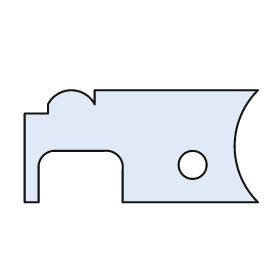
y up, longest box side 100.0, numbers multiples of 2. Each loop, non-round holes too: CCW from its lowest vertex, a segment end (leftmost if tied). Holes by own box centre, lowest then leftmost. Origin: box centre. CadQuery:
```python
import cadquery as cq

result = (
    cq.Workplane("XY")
    .moveTo(-50.0, -24.0)
    .lineTo(-44.0, -24.0)
    .lineTo(-44.0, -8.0)
    .threePointArc((-42.0, -4.0), (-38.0, -2.0))
    .lineTo(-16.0, -2.0)
    .threePointArc((-10.0, -4.0), (-8.0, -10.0))
    .lineTo(-8.0, -24.0)
    .lineTo(50.0, -24.0)
    .threePointArc((40.0, 0.0), (50.0, 24.0))
    .lineTo(-20.0, 24.0)
    .lineTo(-20.0, 18.0)
    .threePointArc((-30.0, 24.0), (-40.0, 18.0))
    .lineTo(-40.0, 14.0)
    .lineTo(-50.0, 14.0)
    .close()
    .moveTo(22.0, -8.0)
    .circle(6.0)
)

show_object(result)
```